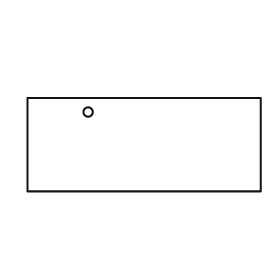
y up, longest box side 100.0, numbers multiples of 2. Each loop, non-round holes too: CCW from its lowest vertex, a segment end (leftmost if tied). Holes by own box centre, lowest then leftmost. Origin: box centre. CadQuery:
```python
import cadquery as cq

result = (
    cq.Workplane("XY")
    .moveTo(-50.0, -20.0)
    .lineTo(50.0, -20.0)
    .lineTo(50.0, 20.0)
    .lineTo(-50.0, 20.0)
    .close()
    .moveTo(-24.0, 14.0)
    .circle(2.0)
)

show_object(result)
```